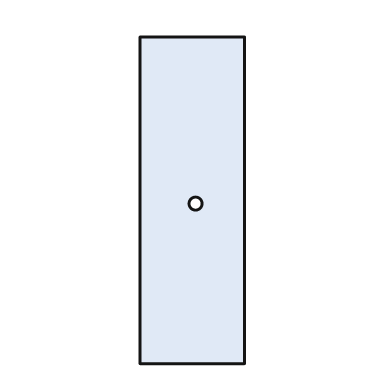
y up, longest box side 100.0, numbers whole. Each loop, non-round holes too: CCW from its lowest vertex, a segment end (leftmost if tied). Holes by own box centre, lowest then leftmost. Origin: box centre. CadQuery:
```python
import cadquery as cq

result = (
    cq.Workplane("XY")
    .moveTo(-16.0, -50.0)
    .lineTo(16.0, -50.0)
    .lineTo(16.0, 50.0)
    .lineTo(-16.0, 50.0)
    .close()
    .moveTo(1.0, -1.0)
    .circle(2.0)
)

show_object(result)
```